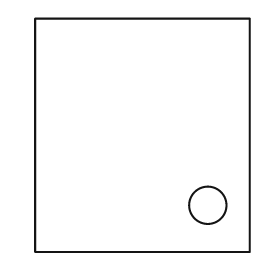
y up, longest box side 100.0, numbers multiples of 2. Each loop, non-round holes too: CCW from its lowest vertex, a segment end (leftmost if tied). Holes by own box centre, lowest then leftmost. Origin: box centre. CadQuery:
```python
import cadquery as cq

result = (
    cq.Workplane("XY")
    .moveTo(-46.0, -50.0)
    .lineTo(46.0, -50.0)
    .lineTo(46.0, 50.0)
    .lineTo(-46.0, 50.0)
    .close()
    .moveTo(28.0, -30.0)
    .circle(8.0)
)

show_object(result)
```